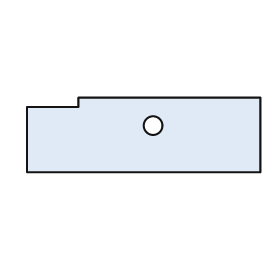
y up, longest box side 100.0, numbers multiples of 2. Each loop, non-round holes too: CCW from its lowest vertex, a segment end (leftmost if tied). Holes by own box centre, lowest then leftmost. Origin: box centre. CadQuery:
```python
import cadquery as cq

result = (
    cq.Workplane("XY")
    .moveTo(-50.0, -16.0)
    .lineTo(50.0, -16.0)
    .lineTo(50.0, 16.0)
    .lineTo(-28.0, 16.0)
    .lineTo(-28.0, 12.0)
    .lineTo(-50.0, 12.0)
    .close()
    .moveTo(4.0, 4.0)
    .circle(4.0)
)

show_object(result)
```